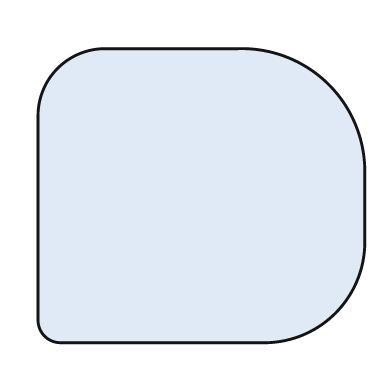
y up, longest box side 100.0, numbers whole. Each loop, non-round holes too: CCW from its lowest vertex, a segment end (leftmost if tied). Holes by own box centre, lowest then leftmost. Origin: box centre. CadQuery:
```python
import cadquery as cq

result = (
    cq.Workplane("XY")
    .moveTo(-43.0, -45.0)
    .lineTo(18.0, -45.0)
    .threePointArc((41.0, -36.0), (50.0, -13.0))
    .lineTo(50.0, 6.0)
    .threePointArc((39.0, 34.0), (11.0, 45.0))
    .lineTo(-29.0, 45.0)
    .threePointArc((-44.0, 39.0), (-50.0, 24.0))
    .lineTo(-50.0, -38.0)
    .threePointArc((-48.0, -43.0), (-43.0, -45.0))
    .close()
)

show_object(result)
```